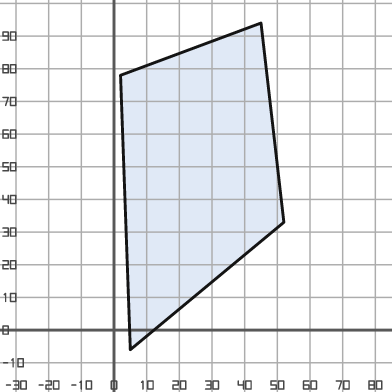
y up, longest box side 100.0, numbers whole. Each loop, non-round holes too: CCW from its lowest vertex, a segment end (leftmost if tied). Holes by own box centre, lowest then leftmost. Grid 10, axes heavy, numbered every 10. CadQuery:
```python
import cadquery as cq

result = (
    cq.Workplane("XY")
    .moveTo(5.0, -6.0)
    .lineTo(52.0, 33.0)
    .lineTo(45.0, 94.0)
    .lineTo(2.0, 78.0)
    .close()
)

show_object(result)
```